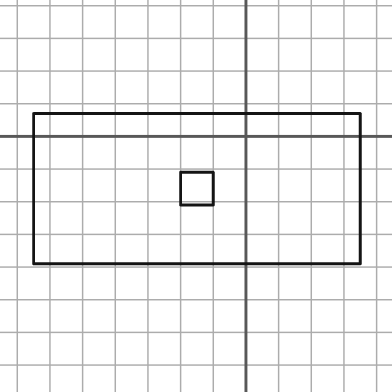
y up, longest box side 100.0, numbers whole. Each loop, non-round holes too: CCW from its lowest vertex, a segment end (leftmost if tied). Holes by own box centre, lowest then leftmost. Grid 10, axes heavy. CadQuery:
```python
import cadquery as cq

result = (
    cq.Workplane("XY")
    .moveTo(-65.0, -39.0)
    .lineTo(35.0, -39.0)
    .lineTo(35.0, 7.0)
    .lineTo(-65.0, 7.0)
    .close()
    .moveTo(-20.0, -21.0)
    .lineTo(-10.0, -21.0)
    .lineTo(-10.0, -11.0)
    .lineTo(-20.0, -11.0)
    .close()
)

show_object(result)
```